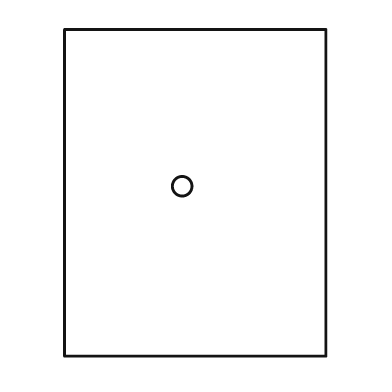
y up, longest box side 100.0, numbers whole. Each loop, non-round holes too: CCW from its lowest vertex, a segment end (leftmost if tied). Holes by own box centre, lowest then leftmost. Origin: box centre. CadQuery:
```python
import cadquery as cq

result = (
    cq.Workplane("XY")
    .moveTo(-40.0, -50.0)
    .lineTo(40.0, -50.0)
    .lineTo(40.0, 50.0)
    .lineTo(-40.0, 50.0)
    .close()
    .moveTo(-4.0, 2.0)
    .circle(3.0)
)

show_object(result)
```